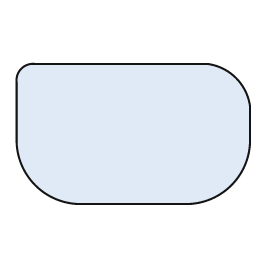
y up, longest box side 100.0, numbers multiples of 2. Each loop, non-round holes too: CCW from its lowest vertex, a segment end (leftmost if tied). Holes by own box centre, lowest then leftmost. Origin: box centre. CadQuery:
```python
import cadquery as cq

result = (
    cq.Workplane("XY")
    .moveTo(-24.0, -30.0)
    .lineTo(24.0, -30.0)
    .threePointArc((42.0, -22.0), (50.0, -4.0))
    .lineTo(50.0, 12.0)
    .threePointArc((44.0, 24.0), (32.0, 30.0))
    .lineTo(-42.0, 30.0)
    .threePointArc((-48.0, 28.0), (-50.0, 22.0))
    .lineTo(-50.0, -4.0)
    .threePointArc((-42.0, -22.0), (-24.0, -30.0))
    .close()
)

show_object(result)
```